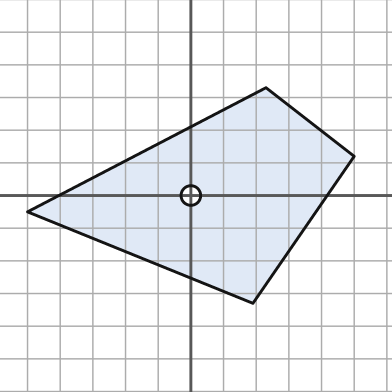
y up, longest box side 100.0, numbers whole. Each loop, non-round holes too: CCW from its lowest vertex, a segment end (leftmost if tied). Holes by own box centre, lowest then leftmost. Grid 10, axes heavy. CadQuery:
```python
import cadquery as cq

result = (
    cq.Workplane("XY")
    .moveTo(19.0, -33.0)
    .lineTo(50.0, 12.0)
    .lineTo(23.0, 33.0)
    .lineTo(-50.0, -5.0)
    .close()
    .moveTo(0.0, 0.0)
    .circle(3.0)
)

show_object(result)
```